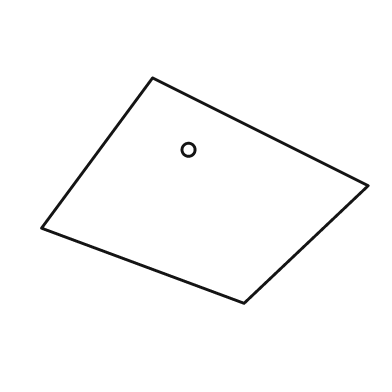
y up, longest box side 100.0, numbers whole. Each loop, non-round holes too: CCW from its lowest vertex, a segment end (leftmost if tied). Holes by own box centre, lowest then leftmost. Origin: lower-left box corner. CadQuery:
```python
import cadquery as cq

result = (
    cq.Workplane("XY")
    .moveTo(62.0, 0.0)
    .lineTo(100.0, 36.0)
    .lineTo(34.0, 69.0)
    .lineTo(0.0, 23.0)
    .close()
    .moveTo(45.0, 47.0)
    .circle(2.0)
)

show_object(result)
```